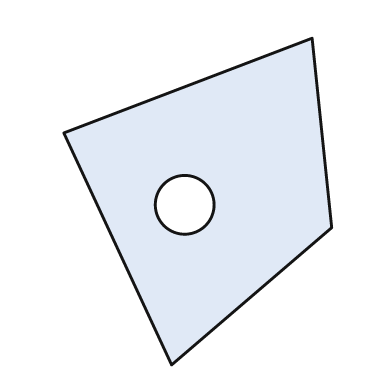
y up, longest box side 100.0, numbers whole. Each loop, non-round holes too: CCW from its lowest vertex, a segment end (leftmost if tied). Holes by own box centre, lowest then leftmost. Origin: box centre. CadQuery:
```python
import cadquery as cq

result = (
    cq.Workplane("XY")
    .moveTo(-8.0, -50.0)
    .lineTo(41.0, -8.0)
    .lineTo(35.0, 50.0)
    .lineTo(-41.0, 21.0)
    .close()
    .moveTo(-4.0, -1.0)
    .circle(9.0)
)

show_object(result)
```